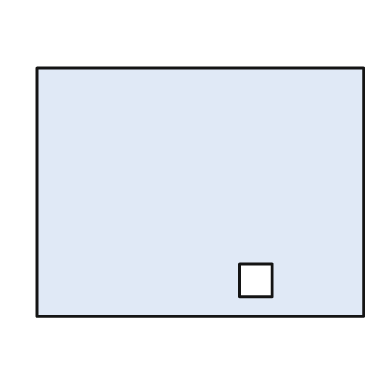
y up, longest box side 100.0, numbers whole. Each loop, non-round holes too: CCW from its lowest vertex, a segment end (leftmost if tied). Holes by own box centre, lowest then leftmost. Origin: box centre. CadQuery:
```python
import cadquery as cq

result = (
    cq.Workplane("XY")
    .moveTo(-50.0, -38.0)
    .lineTo(50.0, -38.0)
    .lineTo(50.0, 38.0)
    .lineTo(-50.0, 38.0)
    .close()
    .moveTo(12.0, -32.0)
    .lineTo(22.0, -32.0)
    .lineTo(22.0, -22.0)
    .lineTo(12.0, -22.0)
    .close()
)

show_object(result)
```